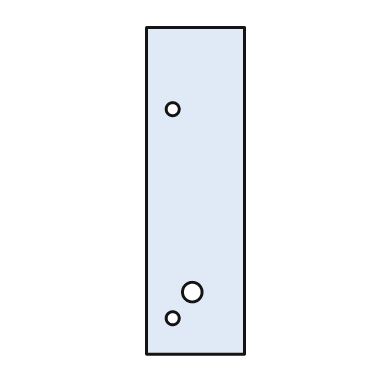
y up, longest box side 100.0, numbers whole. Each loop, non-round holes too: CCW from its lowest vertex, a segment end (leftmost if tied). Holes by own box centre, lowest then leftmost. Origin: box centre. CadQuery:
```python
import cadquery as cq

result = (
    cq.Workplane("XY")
    .moveTo(-15.0, -50.0)
    .lineTo(15.0, -50.0)
    .lineTo(15.0, 50.0)
    .lineTo(-15.0, 50.0)
    .close()
    .moveTo(-7.0, -39.0)
    .circle(2.0)
    .moveTo(-1.0, -31.0)
    .circle(3.0)
    .moveTo(-7.0, 25.0)
    .circle(2.0)
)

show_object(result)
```